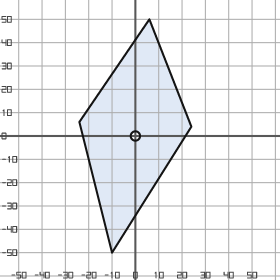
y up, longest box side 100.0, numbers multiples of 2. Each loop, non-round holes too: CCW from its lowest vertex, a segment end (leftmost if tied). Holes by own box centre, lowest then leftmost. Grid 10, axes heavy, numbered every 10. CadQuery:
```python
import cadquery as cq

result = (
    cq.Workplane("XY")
    .moveTo(-10.0, -50.0)
    .lineTo(24.0, 4.0)
    .lineTo(6.0, 50.0)
    .lineTo(-24.0, 6.0)
    .close()
    .moveTo(0.0, 0.0)
    .circle(2.0)
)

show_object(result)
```